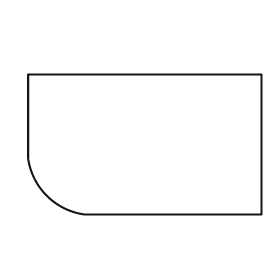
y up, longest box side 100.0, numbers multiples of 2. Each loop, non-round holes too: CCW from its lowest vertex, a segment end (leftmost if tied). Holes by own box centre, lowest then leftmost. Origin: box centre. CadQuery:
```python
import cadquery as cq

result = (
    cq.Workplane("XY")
    .moveTo(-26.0, -30.0)
    .lineTo(50.0, -30.0)
    .lineTo(50.0, 30.0)
    .lineTo(-50.0, 30.0)
    .lineTo(-50.0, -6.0)
    .threePointArc((-42.0, -22.0), (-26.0, -30.0))
    .close()
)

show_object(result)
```